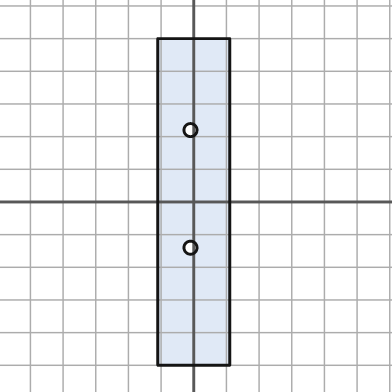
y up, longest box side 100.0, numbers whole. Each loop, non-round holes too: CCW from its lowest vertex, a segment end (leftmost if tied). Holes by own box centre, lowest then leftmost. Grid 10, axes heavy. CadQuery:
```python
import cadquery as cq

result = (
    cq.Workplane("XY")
    .moveTo(-11.0, -50.0)
    .lineTo(11.0, -50.0)
    .lineTo(11.0, 50.0)
    .lineTo(-11.0, 50.0)
    .close()
    .moveTo(-1.0, -14.0)
    .circle(2.0)
    .moveTo(-1.0, 22.0)
    .circle(2.0)
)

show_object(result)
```